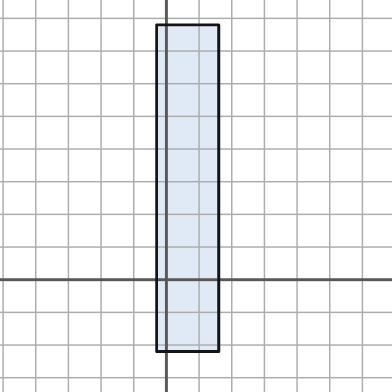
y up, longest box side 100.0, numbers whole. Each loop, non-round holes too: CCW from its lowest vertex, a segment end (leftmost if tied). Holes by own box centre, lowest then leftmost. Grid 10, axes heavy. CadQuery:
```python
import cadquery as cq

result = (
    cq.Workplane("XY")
    .moveTo(-3.0, -22.0)
    .lineTo(16.0, -22.0)
    .lineTo(16.0, 78.0)
    .lineTo(-3.0, 78.0)
    .close()
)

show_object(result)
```